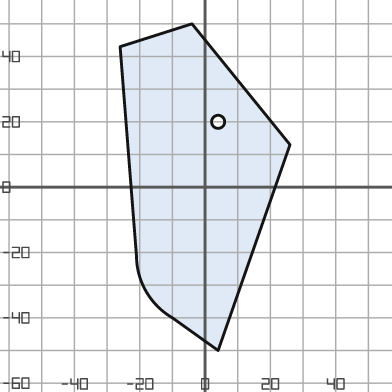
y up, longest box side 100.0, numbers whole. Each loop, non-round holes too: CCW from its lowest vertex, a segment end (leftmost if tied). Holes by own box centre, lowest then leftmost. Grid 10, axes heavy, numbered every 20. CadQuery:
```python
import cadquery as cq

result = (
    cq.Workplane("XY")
    .moveTo(4.0, -50.0)
    .lineTo(26.0, 13.0)
    .lineTo(-4.0, 50.0)
    .lineTo(-26.0, 43.0)
    .lineTo(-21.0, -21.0)
    .threePointArc((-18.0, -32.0), (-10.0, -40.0))
    .close()
    .moveTo(4.0, 20.0)
    .circle(2.0)
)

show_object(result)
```